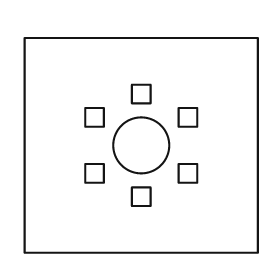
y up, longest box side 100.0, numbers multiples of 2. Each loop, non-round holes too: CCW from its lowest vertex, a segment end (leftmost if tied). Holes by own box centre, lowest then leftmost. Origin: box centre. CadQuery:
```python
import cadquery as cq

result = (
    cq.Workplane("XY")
    .moveTo(-50.0, -46.0)
    .lineTo(50.0, -46.0)
    .lineTo(50.0, 46.0)
    .lineTo(-50.0, 46.0)
    .close()
    .moveTo(-4.0, -26.0)
    .lineTo(4.0, -26.0)
    .lineTo(4.0, -18.0)
    .lineTo(-4.0, -18.0)
    .close()
    .moveTo(-24.0, -16.0)
    .lineTo(-16.0, -16.0)
    .lineTo(-16.0, -8.0)
    .lineTo(-24.0, -8.0)
    .close()
    .moveTo(16.0, -16.0)
    .lineTo(24.0, -16.0)
    .lineTo(24.0, -8.0)
    .lineTo(16.0, -8.0)
    .close()
    .moveTo(0.0, 0.0)
    .circle(12.0)
    .moveTo(-24.0, 8.0)
    .lineTo(-16.0, 8.0)
    .lineTo(-16.0, 16.0)
    .lineTo(-24.0, 16.0)
    .close()
    .moveTo(16.0, 8.0)
    .lineTo(24.0, 8.0)
    .lineTo(24.0, 16.0)
    .lineTo(16.0, 16.0)
    .close()
    .moveTo(-4.0, 18.0)
    .lineTo(4.0, 18.0)
    .lineTo(4.0, 26.0)
    .lineTo(-4.0, 26.0)
    .close()
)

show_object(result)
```